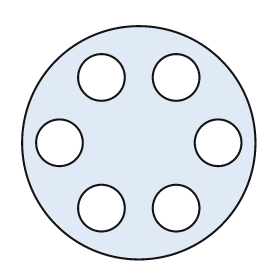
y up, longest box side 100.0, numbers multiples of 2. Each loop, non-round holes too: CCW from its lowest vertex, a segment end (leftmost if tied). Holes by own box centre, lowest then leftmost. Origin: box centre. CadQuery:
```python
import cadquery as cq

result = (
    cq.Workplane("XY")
    .moveTo(0.0, 0.0)
    .circle(50.0)
    .moveTo(-16.0, -28.0)
    .circle(10.0)
    .moveTo(16.0, -28.0)
    .circle(10.0)
    .moveTo(-34.0, 0.0)
    .circle(10.0)
    .moveTo(34.0, 0.0)
    .circle(10.0)
    .moveTo(-16.0, 28.0)
    .circle(10.0)
    .moveTo(16.0, 28.0)
    .circle(10.0)
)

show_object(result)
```